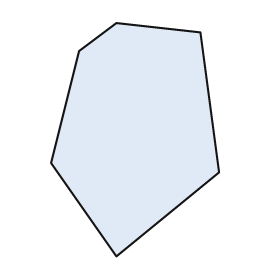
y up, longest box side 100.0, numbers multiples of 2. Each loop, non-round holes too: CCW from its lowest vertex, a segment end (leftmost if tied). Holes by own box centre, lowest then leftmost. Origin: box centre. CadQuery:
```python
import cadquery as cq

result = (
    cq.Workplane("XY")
    .moveTo(-8.0, -50.0)
    .lineTo(36.0, -14.0)
    .lineTo(28.0, 46.0)
    .lineTo(-8.0, 50.0)
    .lineTo(-24.0, 38.0)
    .lineTo(-36.0, -10.0)
    .close()
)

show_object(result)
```